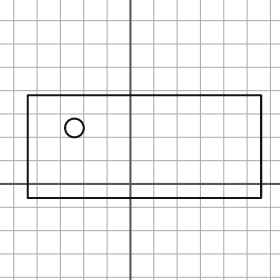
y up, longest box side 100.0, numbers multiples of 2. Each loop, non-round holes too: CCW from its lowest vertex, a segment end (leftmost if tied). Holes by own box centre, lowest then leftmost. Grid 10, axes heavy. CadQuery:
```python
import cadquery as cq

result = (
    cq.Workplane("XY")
    .moveTo(-44.0, -6.0)
    .lineTo(56.0, -6.0)
    .lineTo(56.0, 38.0)
    .lineTo(-44.0, 38.0)
    .close()
    .moveTo(-24.0, 24.0)
    .circle(4.0)
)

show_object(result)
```